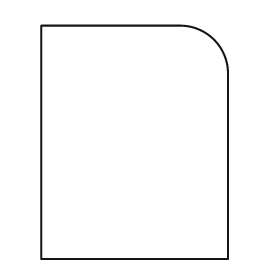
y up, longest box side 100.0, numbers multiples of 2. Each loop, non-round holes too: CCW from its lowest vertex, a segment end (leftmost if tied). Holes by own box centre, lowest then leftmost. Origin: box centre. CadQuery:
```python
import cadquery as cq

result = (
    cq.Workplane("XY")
    .moveTo(-40.0, -50.0)
    .lineTo(40.0, -50.0)
    .lineTo(40.0, 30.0)
    .threePointArc((34.0, 44.0), (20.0, 50.0))
    .lineTo(-40.0, 50.0)
    .close()
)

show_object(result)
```